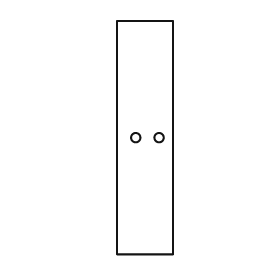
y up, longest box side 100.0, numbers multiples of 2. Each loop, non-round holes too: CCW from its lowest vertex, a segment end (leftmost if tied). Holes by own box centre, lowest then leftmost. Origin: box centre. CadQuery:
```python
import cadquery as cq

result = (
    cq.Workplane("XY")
    .moveTo(-12.0, -50.0)
    .lineTo(12.0, -50.0)
    .lineTo(12.0, 50.0)
    .lineTo(-12.0, 50.0)
    .close()
    .moveTo(-4.0, 0.0)
    .circle(2.0)
    .moveTo(6.0, 0.0)
    .circle(2.0)
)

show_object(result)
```